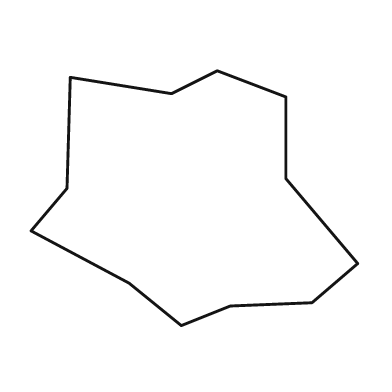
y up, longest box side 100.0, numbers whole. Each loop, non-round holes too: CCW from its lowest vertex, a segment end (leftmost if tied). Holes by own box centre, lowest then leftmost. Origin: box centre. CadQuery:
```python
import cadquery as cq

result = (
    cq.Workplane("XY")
    .moveTo(-4.0, -39.0)
    .lineTo(11.0, -33.0)
    .lineTo(36.0, -32.0)
    .lineTo(50.0, -20.0)
    .lineTo(28.0, 6.0)
    .lineTo(28.0, 31.0)
    .lineTo(7.0, 39.0)
    .lineTo(-7.0, 32.0)
    .lineTo(-38.0, 37.0)
    .lineTo(-39.0, 3.0)
    .lineTo(-50.0, -10.0)
    .lineTo(-20.0, -26.0)
    .close()
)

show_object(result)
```